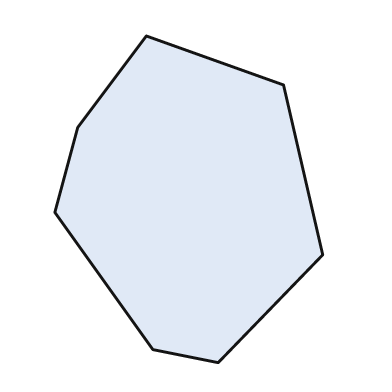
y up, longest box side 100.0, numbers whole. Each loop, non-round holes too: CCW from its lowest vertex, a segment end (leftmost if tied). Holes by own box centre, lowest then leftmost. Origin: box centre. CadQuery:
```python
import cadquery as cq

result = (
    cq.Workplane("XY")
    .moveTo(9.0, -50.0)
    .lineTo(41.0, -17.0)
    .lineTo(29.0, 35.0)
    .lineTo(-13.0, 50.0)
    .lineTo(-34.0, 22.0)
    .lineTo(-41.0, -4.0)
    .lineTo(-11.0, -46.0)
    .close()
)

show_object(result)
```